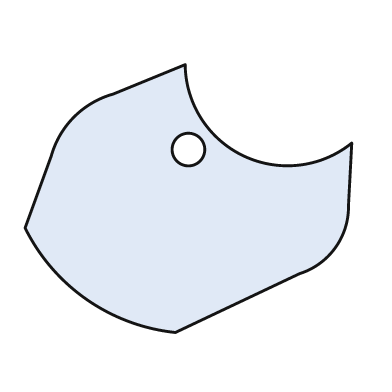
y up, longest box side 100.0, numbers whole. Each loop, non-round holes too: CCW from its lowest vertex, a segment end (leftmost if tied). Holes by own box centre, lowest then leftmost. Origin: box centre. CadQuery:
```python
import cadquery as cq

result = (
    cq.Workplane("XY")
    .moveTo(-4.0, -41.0)
    .lineTo(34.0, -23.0)
    .threePointArc((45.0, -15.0), (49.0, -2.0))
    .lineTo(50.0, 17.0)
    .threePointArc((17.0, 13.0), (-1.0, 41.0))
    .lineTo(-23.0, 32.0)
    .threePointArc((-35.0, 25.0), (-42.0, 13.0))
    .lineTo(-50.0, -9.0)
    .threePointArc((-31.0, -31.0), (-4.0, -41.0))
    .close()
    .moveTo(0.0, 15.0)
    .circle(5.0)
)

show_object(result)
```